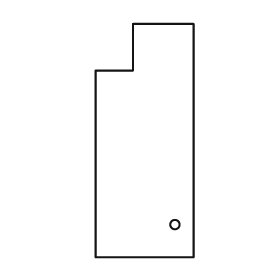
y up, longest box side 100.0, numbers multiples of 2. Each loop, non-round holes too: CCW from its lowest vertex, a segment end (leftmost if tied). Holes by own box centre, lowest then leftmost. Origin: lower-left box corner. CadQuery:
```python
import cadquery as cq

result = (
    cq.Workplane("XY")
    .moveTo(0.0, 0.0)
    .lineTo(42.0, 0.0)
    .lineTo(42.0, 100.0)
    .lineTo(16.0, 100.0)
    .lineTo(16.0, 80.0)
    .lineTo(0.0, 80.0)
    .close()
    .moveTo(34.0, 14.0)
    .circle(2.0)
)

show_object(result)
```